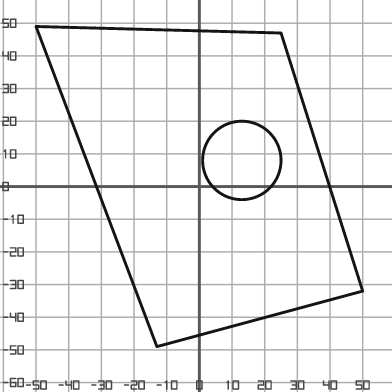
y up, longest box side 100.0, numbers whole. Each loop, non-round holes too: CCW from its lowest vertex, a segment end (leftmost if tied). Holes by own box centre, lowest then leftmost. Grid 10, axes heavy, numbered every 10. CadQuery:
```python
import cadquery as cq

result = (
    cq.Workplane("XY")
    .moveTo(-13.0, -49.0)
    .lineTo(50.0, -32.0)
    .lineTo(25.0, 47.0)
    .lineTo(-50.0, 49.0)
    .close()
    .moveTo(13.0, 8.0)
    .circle(12.0)
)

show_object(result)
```